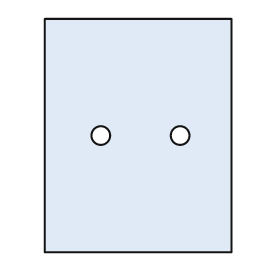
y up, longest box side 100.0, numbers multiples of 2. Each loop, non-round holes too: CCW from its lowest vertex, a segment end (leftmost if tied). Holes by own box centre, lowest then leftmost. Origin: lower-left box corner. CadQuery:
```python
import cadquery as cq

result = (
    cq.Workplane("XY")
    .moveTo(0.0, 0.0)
    .lineTo(80.0, 0.0)
    .lineTo(80.0, 100.0)
    .lineTo(0.0, 100.0)
    .close()
    .moveTo(24.0, 50.0)
    .circle(4.0)
    .moveTo(58.0, 50.0)
    .circle(4.0)
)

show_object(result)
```